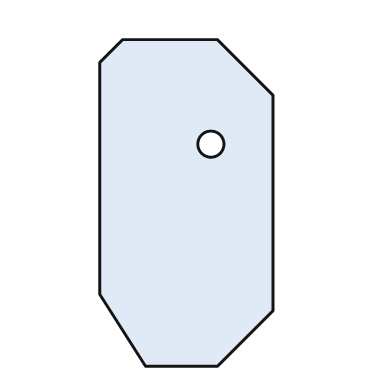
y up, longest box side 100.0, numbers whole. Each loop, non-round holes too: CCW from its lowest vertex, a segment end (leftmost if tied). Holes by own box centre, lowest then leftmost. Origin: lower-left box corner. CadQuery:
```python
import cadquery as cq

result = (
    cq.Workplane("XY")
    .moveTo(14.0, 0.0)
    .lineTo(36.0, 0.0)
    .lineTo(53.0, 17.0)
    .lineTo(53.0, 83.0)
    .lineTo(36.0, 100.0)
    .lineTo(7.0, 100.0)
    .lineTo(0.0, 93.0)
    .lineTo(0.0, 22.0)
    .close()
    .moveTo(34.0, 68.0)
    .circle(4.0)
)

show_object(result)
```